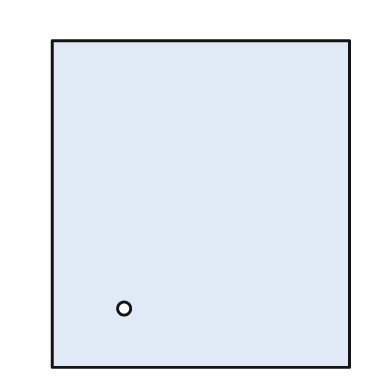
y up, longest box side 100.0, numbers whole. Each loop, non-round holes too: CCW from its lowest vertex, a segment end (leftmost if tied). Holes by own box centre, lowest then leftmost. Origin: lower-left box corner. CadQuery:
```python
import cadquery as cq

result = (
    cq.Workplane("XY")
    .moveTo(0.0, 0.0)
    .lineTo(91.0, 0.0)
    .lineTo(91.0, 100.0)
    .lineTo(0.0, 100.0)
    .close()
    .moveTo(22.0, 18.0)
    .circle(2.0)
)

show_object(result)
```